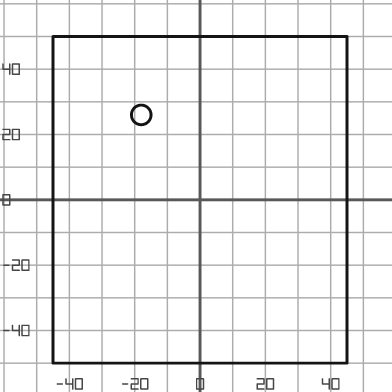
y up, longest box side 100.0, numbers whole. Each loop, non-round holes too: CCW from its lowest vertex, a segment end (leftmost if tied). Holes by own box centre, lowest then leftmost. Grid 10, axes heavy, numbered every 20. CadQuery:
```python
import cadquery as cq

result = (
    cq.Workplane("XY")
    .moveTo(-45.0, -50.0)
    .lineTo(45.0, -50.0)
    .lineTo(45.0, 50.0)
    .lineTo(-45.0, 50.0)
    .close()
    .moveTo(-18.0, 26.0)
    .circle(3.0)
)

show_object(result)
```